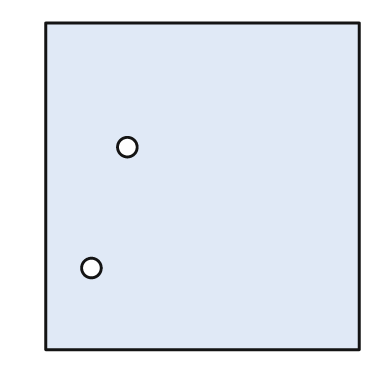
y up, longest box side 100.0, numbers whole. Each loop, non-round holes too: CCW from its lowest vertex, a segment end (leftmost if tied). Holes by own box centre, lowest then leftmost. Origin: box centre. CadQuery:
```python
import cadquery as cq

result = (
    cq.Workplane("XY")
    .moveTo(-48.0, -50.0)
    .lineTo(48.0, -50.0)
    .lineTo(48.0, 50.0)
    .lineTo(-48.0, 50.0)
    .close()
    .moveTo(-34.0, -25.0)
    .circle(3.0)
    .moveTo(-23.0, 12.0)
    .circle(3.0)
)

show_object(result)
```